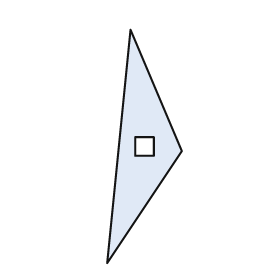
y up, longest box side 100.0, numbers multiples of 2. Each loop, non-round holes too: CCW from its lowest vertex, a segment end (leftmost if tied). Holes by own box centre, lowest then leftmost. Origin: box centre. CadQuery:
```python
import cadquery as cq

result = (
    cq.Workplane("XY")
    .moveTo(-16.0, -50.0)
    .lineTo(16.0, -2.0)
    .lineTo(-6.0, 50.0)
    .close()
    .moveTo(-4.0, -4.0)
    .lineTo(4.0, -4.0)
    .lineTo(4.0, 4.0)
    .lineTo(-4.0, 4.0)
    .close()
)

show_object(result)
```